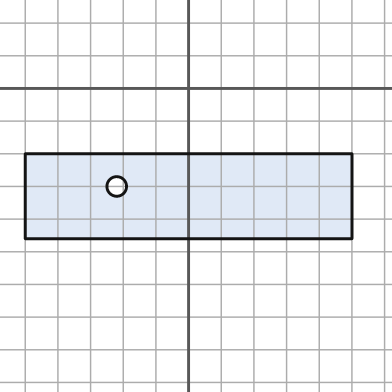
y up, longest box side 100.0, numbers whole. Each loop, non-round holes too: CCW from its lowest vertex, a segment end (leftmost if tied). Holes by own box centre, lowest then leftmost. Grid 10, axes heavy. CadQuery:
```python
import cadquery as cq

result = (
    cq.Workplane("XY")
    .moveTo(-50.0, -46.0)
    .lineTo(50.0, -46.0)
    .lineTo(50.0, -20.0)
    .lineTo(-50.0, -20.0)
    .close()
    .moveTo(-22.0, -30.0)
    .circle(3.0)
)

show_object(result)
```